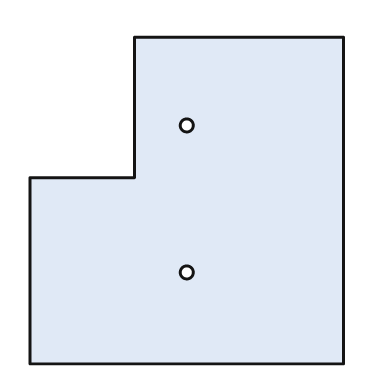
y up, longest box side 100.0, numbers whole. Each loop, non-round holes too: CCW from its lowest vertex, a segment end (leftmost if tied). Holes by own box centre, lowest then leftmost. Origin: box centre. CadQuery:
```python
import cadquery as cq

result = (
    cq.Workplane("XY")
    .moveTo(-48.0, -50.0)
    .lineTo(48.0, -50.0)
    .lineTo(48.0, 50.0)
    .lineTo(-16.0, 50.0)
    .lineTo(-16.0, 7.0)
    .lineTo(-48.0, 7.0)
    .close()
    .moveTo(0.0, -22.0)
    .circle(2.0)
    .moveTo(0.0, 23.0)
    .circle(2.0)
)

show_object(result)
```